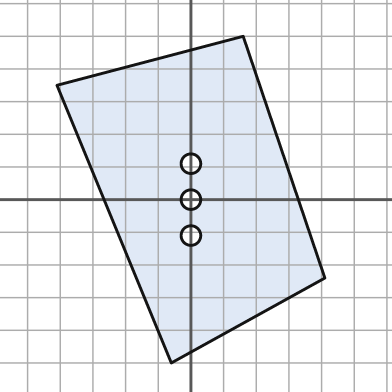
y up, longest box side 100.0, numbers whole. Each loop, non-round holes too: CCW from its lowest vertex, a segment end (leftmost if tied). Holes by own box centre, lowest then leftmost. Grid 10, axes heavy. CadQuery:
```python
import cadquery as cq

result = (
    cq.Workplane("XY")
    .moveTo(-6.0, -50.0)
    .lineTo(41.0, -24.0)
    .lineTo(16.0, 50.0)
    .lineTo(-41.0, 35.0)
    .close()
    .moveTo(0.0, -11.0)
    .circle(3.0)
    .moveTo(0.0, 0.0)
    .circle(3.0)
    .moveTo(0.0, 11.0)
    .circle(3.0)
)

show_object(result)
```